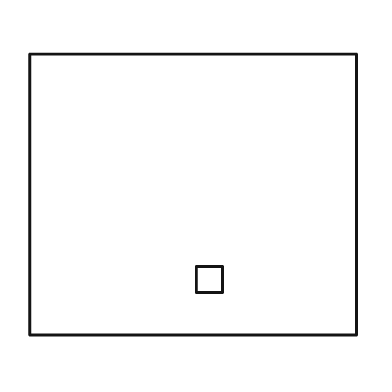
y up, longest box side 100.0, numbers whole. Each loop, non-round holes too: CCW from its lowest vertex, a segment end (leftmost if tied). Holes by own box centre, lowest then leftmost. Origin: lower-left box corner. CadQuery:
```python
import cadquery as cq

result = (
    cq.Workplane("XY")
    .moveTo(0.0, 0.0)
    .lineTo(100.0, 0.0)
    .lineTo(100.0, 86.0)
    .lineTo(0.0, 86.0)
    .close()
    .moveTo(51.0, 13.0)
    .lineTo(59.0, 13.0)
    .lineTo(59.0, 21.0)
    .lineTo(51.0, 21.0)
    .close()
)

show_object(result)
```